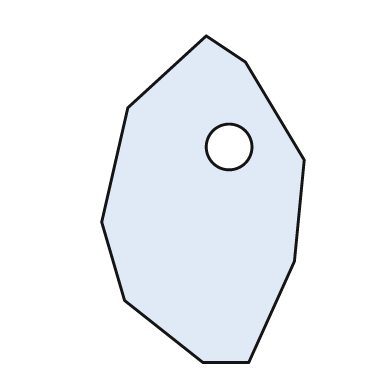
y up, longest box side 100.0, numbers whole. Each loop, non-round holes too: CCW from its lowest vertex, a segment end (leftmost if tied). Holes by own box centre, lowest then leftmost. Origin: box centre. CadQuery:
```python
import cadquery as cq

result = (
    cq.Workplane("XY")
    .moveTo(0.0, -50.0)
    .lineTo(14.0, -50.0)
    .lineTo(28.0, -19.0)
    .lineTo(31.0, 12.0)
    .lineTo(13.0, 42.0)
    .lineTo(1.0, 50.0)
    .lineTo(-23.0, 28.0)
    .lineTo(-31.0, -7.0)
    .lineTo(-24.0, -31.0)
    .close()
    .moveTo(8.0, 16.0)
    .circle(7.0)
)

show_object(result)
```